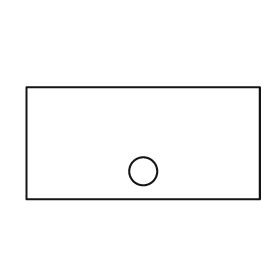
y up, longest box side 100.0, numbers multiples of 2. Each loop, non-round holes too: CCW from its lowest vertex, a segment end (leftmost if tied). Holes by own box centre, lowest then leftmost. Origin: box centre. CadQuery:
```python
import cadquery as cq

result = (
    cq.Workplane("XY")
    .moveTo(-50.0, -24.0)
    .lineTo(50.0, -24.0)
    .lineTo(50.0, 24.0)
    .lineTo(-50.0, 24.0)
    .close()
    .moveTo(0.0, -12.0)
    .circle(6.0)
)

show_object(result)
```